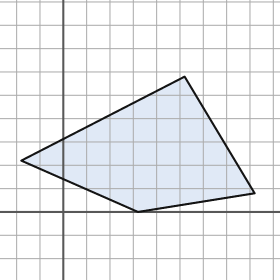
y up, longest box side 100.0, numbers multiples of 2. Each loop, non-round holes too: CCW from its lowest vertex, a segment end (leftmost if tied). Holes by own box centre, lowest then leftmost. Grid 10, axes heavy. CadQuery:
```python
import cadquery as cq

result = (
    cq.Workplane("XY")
    .moveTo(32.0, 0.0)
    .lineTo(82.0, 8.0)
    .lineTo(52.0, 58.0)
    .lineTo(-18.0, 22.0)
    .close()
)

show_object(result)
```